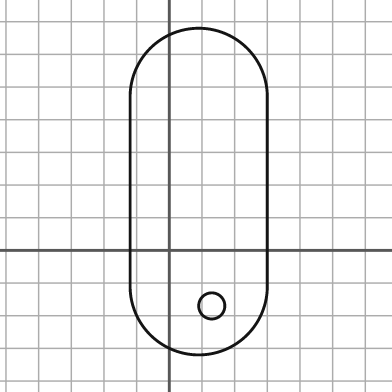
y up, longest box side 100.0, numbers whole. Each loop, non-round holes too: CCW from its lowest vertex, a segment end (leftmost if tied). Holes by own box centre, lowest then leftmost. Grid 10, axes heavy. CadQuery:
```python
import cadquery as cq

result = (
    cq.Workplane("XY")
    .moveTo(-12.0, -11.0)
    .threePointArc((9.0, -32.0), (30.0, -11.0))
    .lineTo(30.0, 47.0)
    .threePointArc((9.0, 68.0), (-12.0, 47.0))
    .close()
    .moveTo(13.0, -17.0)
    .circle(4.0)
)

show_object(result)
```